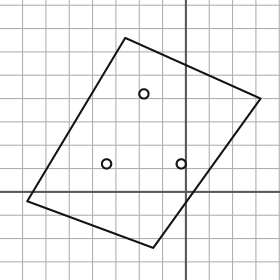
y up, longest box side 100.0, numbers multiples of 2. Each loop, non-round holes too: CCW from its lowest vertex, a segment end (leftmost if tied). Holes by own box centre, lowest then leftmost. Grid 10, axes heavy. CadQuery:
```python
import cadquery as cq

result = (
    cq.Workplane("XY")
    .moveTo(-14.0, -24.0)
    .lineTo(32.0, 40.0)
    .lineTo(-26.0, 66.0)
    .lineTo(-68.0, -4.0)
    .close()
    .moveTo(-34.0, 12.0)
    .circle(2.0)
    .moveTo(-2.0, 12.0)
    .circle(2.0)
    .moveTo(-18.0, 42.0)
    .circle(2.0)
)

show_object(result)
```